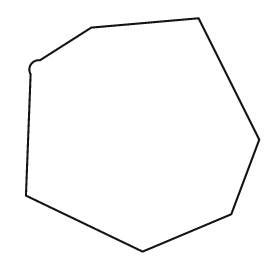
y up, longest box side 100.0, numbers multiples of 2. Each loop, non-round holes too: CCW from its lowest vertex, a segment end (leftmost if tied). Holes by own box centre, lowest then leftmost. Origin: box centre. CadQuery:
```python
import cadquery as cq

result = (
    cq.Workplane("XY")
    .moveTo(0.0, -50.0)
    .lineTo(38.0, -34.0)
    .lineTo(50.0, -2.0)
    .lineTo(24.0, 50.0)
    .lineTo(-22.0, 46.0)
    .lineTo(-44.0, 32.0)
    .threePointArc((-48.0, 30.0), (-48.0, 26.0))
    .lineTo(-50.0, -26.0)
    .close()
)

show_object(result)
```